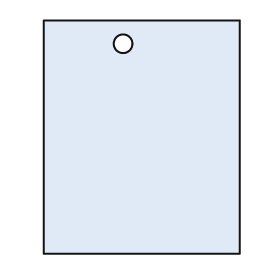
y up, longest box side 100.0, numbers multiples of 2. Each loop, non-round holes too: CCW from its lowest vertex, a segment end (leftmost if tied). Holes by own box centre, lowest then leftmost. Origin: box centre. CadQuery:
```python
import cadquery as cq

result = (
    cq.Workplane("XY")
    .moveTo(-42.0, -50.0)
    .lineTo(42.0, -50.0)
    .lineTo(42.0, 50.0)
    .lineTo(-42.0, 50.0)
    .close()
    .moveTo(-8.0, 40.0)
    .circle(4.0)
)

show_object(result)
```